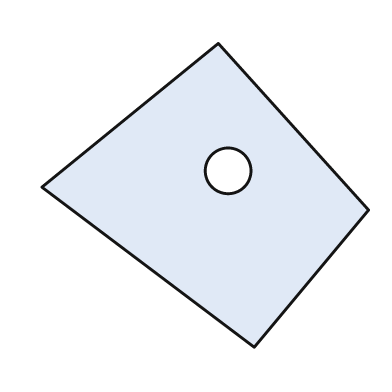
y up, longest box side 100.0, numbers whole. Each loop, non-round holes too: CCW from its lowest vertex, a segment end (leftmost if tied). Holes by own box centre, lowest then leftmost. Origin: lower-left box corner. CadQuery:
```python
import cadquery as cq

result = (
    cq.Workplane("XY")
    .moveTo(65.0, 0.0)
    .lineTo(100.0, 42.0)
    .lineTo(54.0, 93.0)
    .lineTo(0.0, 49.0)
    .close()
    .moveTo(57.0, 54.0)
    .circle(7.0)
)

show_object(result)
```